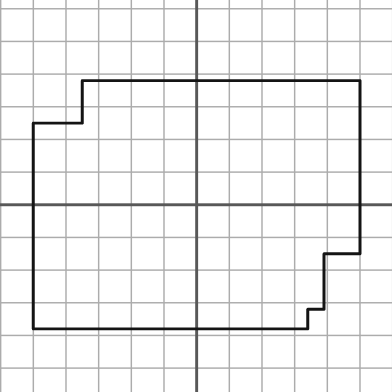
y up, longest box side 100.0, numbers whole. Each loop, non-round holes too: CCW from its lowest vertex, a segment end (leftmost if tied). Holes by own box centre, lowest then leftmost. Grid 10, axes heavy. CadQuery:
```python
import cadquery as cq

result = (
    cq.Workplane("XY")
    .moveTo(-50.0, -38.0)
    .lineTo(34.0, -38.0)
    .lineTo(34.0, -32.0)
    .lineTo(39.0, -32.0)
    .lineTo(39.0, -15.0)
    .lineTo(50.0, -15.0)
    .lineTo(50.0, 38.0)
    .lineTo(-35.0, 38.0)
    .lineTo(-35.0, 25.0)
    .lineTo(-50.0, 25.0)
    .close()
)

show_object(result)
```